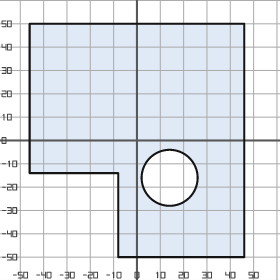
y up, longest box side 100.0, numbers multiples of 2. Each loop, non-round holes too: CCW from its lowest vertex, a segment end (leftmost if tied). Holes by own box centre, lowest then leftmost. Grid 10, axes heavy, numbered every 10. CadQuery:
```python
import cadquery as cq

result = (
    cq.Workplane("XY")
    .moveTo(-8.0, -50.0)
    .lineTo(46.0, -50.0)
    .lineTo(46.0, 50.0)
    .lineTo(-46.0, 50.0)
    .lineTo(-46.0, -14.0)
    .lineTo(-8.0, -14.0)
    .close()
    .moveTo(14.0, -16.0)
    .circle(12.0)
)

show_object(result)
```